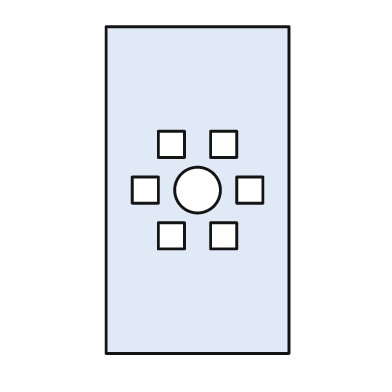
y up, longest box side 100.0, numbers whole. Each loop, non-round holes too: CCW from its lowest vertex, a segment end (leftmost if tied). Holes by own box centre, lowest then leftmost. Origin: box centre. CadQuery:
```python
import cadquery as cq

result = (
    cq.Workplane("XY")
    .moveTo(-28.0, -50.0)
    .lineTo(28.0, -50.0)
    .lineTo(28.0, 50.0)
    .lineTo(-28.0, 50.0)
    .close()
    .moveTo(-12.0, -18.0)
    .lineTo(-4.0, -18.0)
    .lineTo(-4.0, -10.0)
    .lineTo(-12.0, -10.0)
    .close()
    .moveTo(4.0, -18.0)
    .lineTo(12.0, -18.0)
    .lineTo(12.0, -10.0)
    .lineTo(4.0, -10.0)
    .close()
    .moveTo(-20.0, -4.0)
    .lineTo(-12.0, -4.0)
    .lineTo(-12.0, 4.0)
    .lineTo(-20.0, 4.0)
    .close()
    .moveTo(0.0, 0.0)
    .circle(7.0)
    .moveTo(12.0, -4.0)
    .lineTo(20.0, -4.0)
    .lineTo(20.0, 4.0)
    .lineTo(12.0, 4.0)
    .close()
    .moveTo(-12.0, 10.0)
    .lineTo(-4.0, 10.0)
    .lineTo(-4.0, 18.0)
    .lineTo(-12.0, 18.0)
    .close()
    .moveTo(4.0, 10.0)
    .lineTo(12.0, 10.0)
    .lineTo(12.0, 18.0)
    .lineTo(4.0, 18.0)
    .close()
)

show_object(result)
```